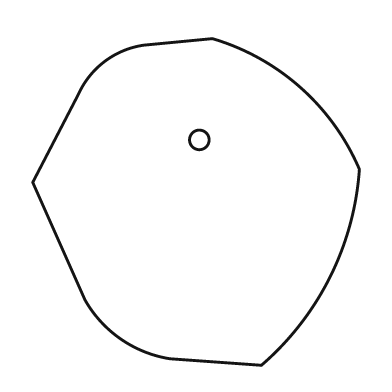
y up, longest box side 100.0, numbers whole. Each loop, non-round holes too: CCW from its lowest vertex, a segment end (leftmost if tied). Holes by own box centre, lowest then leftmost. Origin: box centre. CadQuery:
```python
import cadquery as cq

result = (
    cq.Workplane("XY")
    .moveTo(20.0, -50.0)
    .threePointArc((41.0, -23.0), (50.0, 10.0))
    .threePointArc((32.0, 35.0), (5.0, 50.0))
    .lineTo(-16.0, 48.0)
    .threePointArc((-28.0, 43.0), (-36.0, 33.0))
    .lineTo(-50.0, 6.0)
    .lineTo(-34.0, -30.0)
    .threePointArc((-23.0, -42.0), (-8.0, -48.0))
    .close()
    .moveTo(1.0, 19.0)
    .circle(3.0)
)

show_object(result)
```